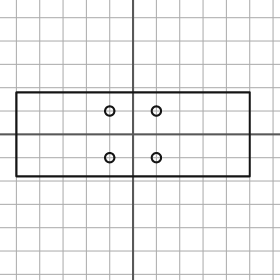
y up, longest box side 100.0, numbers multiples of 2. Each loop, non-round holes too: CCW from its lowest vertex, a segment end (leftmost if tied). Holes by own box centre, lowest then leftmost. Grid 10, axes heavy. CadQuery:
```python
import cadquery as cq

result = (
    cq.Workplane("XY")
    .moveTo(-50.0, -18.0)
    .lineTo(50.0, -18.0)
    .lineTo(50.0, 18.0)
    .lineTo(-50.0, 18.0)
    .close()
    .moveTo(-10.0, -10.0)
    .circle(2.0)
    .moveTo(10.0, -10.0)
    .circle(2.0)
    .moveTo(-10.0, 10.0)
    .circle(2.0)
    .moveTo(10.0, 10.0)
    .circle(2.0)
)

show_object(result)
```